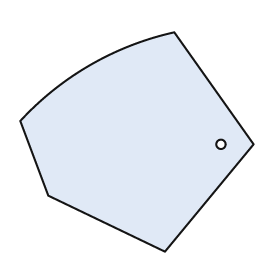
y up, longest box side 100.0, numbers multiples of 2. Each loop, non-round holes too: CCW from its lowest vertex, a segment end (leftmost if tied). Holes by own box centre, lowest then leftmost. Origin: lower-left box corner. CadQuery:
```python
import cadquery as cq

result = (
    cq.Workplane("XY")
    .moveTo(62.0, 0.0)
    .lineTo(100.0, 46.0)
    .lineTo(66.0, 94.0)
    .threePointArc((30.0, 80.0), (0.0, 56.0))
    .lineTo(12.0, 24.0)
    .close()
    .moveTo(86.0, 46.0)
    .circle(2.0)
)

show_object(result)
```